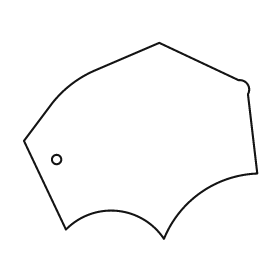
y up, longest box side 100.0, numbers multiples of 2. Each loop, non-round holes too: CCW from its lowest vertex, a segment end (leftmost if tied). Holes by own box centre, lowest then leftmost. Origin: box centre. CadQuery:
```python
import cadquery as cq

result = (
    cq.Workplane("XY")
    .moveTo(10.0, -42.0)
    .threePointArc((26.0, -22.0), (50.0, -14.0))
    .lineTo(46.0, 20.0)
    .threePointArc((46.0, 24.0), (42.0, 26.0))
    .lineTo(8.0, 42.0)
    .lineTo(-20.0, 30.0)
    .threePointArc((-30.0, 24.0), (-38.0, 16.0))
    .lineTo(-50.0, 0.0)
    .lineTo(-32.0, -38.0)
    .threePointArc((-10.0, -30.0), (10.0, -42.0))
    .close()
    .moveTo(-36.0, -8.0)
    .circle(2.0)
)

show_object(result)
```